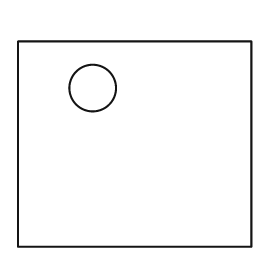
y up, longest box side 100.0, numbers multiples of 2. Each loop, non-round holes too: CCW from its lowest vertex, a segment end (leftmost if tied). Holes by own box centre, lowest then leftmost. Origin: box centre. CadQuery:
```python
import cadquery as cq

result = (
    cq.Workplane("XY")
    .moveTo(-50.0, -44.0)
    .lineTo(50.0, -44.0)
    .lineTo(50.0, 44.0)
    .lineTo(-50.0, 44.0)
    .close()
    .moveTo(-18.0, 24.0)
    .circle(10.0)
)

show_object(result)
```